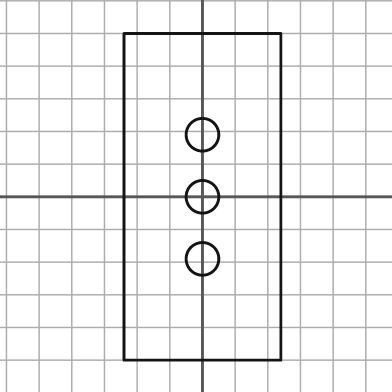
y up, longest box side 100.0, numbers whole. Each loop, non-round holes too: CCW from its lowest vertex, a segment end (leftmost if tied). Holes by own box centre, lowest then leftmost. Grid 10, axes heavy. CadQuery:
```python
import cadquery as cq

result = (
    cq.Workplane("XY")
    .moveTo(-24.0, -50.0)
    .lineTo(24.0, -50.0)
    .lineTo(24.0, 50.0)
    .lineTo(-24.0, 50.0)
    .close()
    .moveTo(0.0, -19.0)
    .circle(5.0)
    .moveTo(0.0, 0.0)
    .circle(5.0)
    .moveTo(0.0, 19.0)
    .circle(5.0)
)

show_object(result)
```